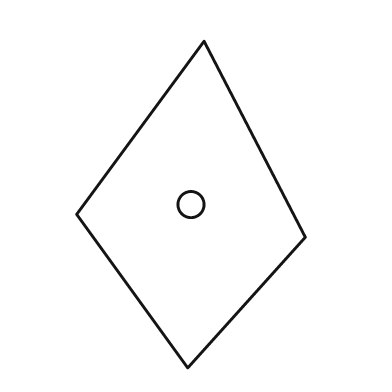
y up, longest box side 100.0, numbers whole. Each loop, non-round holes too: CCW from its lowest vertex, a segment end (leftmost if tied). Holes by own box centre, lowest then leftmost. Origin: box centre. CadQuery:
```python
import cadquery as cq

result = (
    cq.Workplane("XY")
    .moveTo(-1.0, -50.0)
    .lineTo(35.0, -10.0)
    .lineTo(4.0, 50.0)
    .lineTo(-35.0, -3.0)
    .close()
    .moveTo(0.0, 0.0)
    .circle(4.0)
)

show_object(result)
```